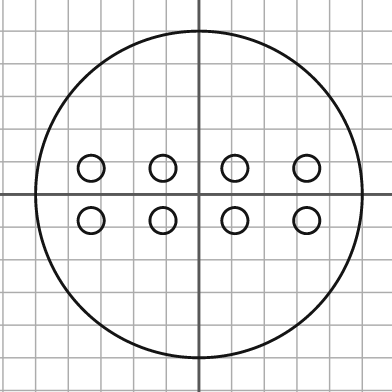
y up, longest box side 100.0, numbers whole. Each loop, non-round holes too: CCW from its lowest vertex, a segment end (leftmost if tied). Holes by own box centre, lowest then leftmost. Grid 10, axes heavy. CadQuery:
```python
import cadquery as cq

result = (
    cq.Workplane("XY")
    .moveTo(0.0, 0.0)
    .circle(50.0)
    .moveTo(-33.0, -8.0)
    .circle(4.0)
    .moveTo(-11.0, -8.0)
    .circle(4.0)
    .moveTo(11.0, -8.0)
    .circle(4.0)
    .moveTo(33.0, -8.0)
    .circle(4.0)
    .moveTo(-33.0, 8.0)
    .circle(4.0)
    .moveTo(-11.0, 8.0)
    .circle(4.0)
    .moveTo(11.0, 8.0)
    .circle(4.0)
    .moveTo(33.0, 8.0)
    .circle(4.0)
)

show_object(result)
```